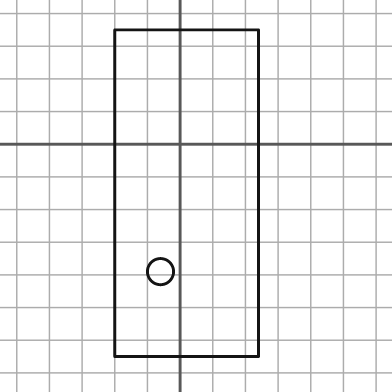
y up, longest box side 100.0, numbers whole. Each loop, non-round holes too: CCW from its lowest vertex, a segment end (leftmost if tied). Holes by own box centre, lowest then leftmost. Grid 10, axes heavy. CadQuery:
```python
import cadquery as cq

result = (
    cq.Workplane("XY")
    .moveTo(-20.0, -65.0)
    .lineTo(24.0, -65.0)
    .lineTo(24.0, 35.0)
    .lineTo(-20.0, 35.0)
    .close()
    .moveTo(-6.0, -39.0)
    .circle(4.0)
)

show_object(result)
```